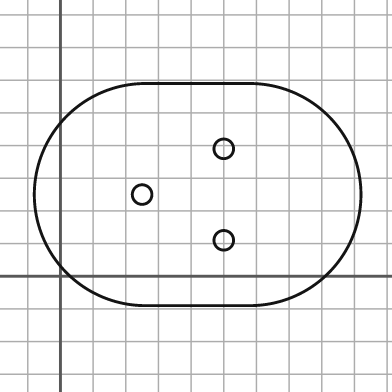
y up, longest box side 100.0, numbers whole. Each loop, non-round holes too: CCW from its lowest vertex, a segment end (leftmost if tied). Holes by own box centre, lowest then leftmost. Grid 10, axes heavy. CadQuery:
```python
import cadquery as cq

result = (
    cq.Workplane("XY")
    .moveTo(26.0, -9.0)
    .lineTo(58.0, -9.0)
    .threePointArc((92.0, 25.0), (58.0, 59.0))
    .lineTo(26.0, 59.0)
    .threePointArc((-8.0, 25.0), (26.0, -9.0))
    .close()
    .moveTo(50.0, 11.0)
    .circle(3.0)
    .moveTo(25.0, 25.0)
    .circle(3.0)
    .moveTo(50.0, 39.0)
    .circle(3.0)
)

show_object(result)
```